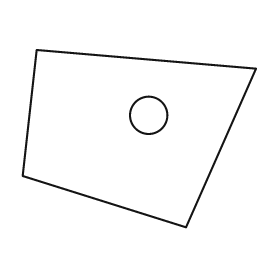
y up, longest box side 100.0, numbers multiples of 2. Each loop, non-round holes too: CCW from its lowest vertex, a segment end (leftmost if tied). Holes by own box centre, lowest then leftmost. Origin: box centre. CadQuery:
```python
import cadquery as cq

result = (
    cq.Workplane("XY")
    .moveTo(20.0, -38.0)
    .lineTo(50.0, 30.0)
    .lineTo(-44.0, 38.0)
    .lineTo(-50.0, -16.0)
    .close()
    .moveTo(4.0, 10.0)
    .circle(8.0)
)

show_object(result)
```